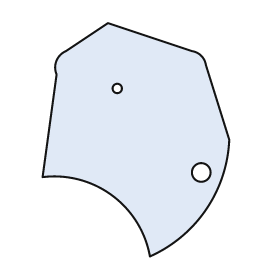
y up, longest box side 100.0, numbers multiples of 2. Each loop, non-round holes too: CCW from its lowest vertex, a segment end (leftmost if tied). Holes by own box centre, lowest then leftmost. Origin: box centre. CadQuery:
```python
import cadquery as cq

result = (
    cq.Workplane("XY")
    .moveTo(6.0, -50.0)
    .threePointArc((30.0, -30.0), (40.0, 0.0))
    .lineTo(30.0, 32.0)
    .threePointArc((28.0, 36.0), (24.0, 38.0))
    .lineTo(-12.0, 50.0)
    .lineTo(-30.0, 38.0)
    .threePointArc((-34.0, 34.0), (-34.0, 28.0))
    .lineTo(-40.0, -16.0)
    .threePointArc((-10.0, -24.0), (6.0, -50.0))
    .close()
    .moveTo(28.0, -14.0)
    .circle(4.0)
    .moveTo(-8.0, 22.0)
    .circle(2.0)
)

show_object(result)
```